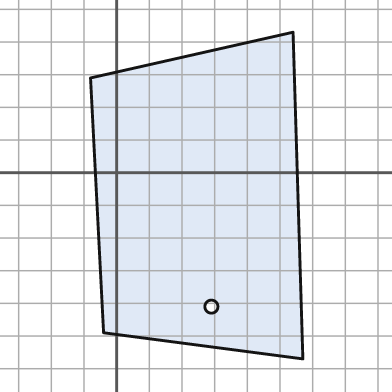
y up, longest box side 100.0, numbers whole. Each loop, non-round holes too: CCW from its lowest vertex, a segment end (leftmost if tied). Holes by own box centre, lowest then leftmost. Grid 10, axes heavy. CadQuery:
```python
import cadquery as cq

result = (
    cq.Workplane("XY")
    .moveTo(57.0, -57.0)
    .lineTo(54.0, 43.0)
    .lineTo(-8.0, 29.0)
    .lineTo(-4.0, -49.0)
    .close()
    .moveTo(29.0, -41.0)
    .circle(2.0)
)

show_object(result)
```